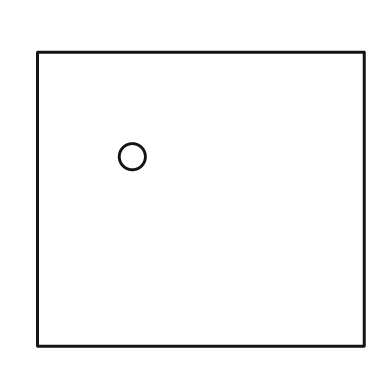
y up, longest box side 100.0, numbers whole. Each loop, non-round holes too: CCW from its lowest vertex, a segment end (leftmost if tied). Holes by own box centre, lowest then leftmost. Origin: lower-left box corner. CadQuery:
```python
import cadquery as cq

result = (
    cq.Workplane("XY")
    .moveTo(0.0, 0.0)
    .lineTo(100.0, 0.0)
    .lineTo(100.0, 90.0)
    .lineTo(0.0, 90.0)
    .close()
    .moveTo(29.0, 58.0)
    .circle(4.0)
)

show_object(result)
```